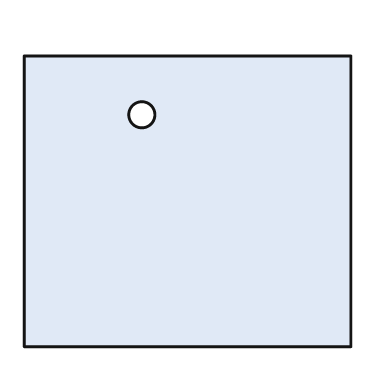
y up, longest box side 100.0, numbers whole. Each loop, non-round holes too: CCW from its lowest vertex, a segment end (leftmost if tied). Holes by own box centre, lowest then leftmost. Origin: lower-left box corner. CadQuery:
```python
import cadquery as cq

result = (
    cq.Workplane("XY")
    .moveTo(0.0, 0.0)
    .lineTo(100.0, 0.0)
    .lineTo(100.0, 89.0)
    .lineTo(0.0, 89.0)
    .close()
    .moveTo(36.0, 71.0)
    .circle(4.0)
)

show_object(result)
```